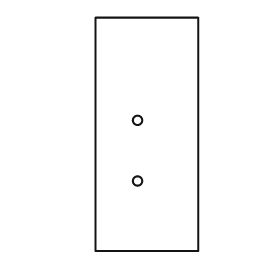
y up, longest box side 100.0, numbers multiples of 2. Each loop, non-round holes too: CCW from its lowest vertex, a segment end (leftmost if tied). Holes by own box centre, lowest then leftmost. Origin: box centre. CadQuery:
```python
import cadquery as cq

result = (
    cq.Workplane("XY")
    .moveTo(-22.0, -50.0)
    .lineTo(22.0, -50.0)
    .lineTo(22.0, 50.0)
    .lineTo(-22.0, 50.0)
    .close()
    .moveTo(-4.0, -20.0)
    .circle(2.0)
    .moveTo(-4.0, 6.0)
    .circle(2.0)
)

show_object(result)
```